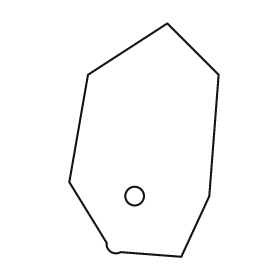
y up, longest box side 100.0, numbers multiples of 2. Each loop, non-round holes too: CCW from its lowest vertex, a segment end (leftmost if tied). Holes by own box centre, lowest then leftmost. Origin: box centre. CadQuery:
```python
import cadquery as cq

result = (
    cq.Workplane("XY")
    .moveTo(16.0, -50.0)
    .lineTo(28.0, -24.0)
    .lineTo(32.0, 28.0)
    .lineTo(10.0, 50.0)
    .lineTo(-24.0, 28.0)
    .lineTo(-32.0, -18.0)
    .lineTo(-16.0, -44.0)
    .threePointArc((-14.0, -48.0), (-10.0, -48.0))
    .close()
    .moveTo(-4.0, -24.0)
    .circle(4.0)
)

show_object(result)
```